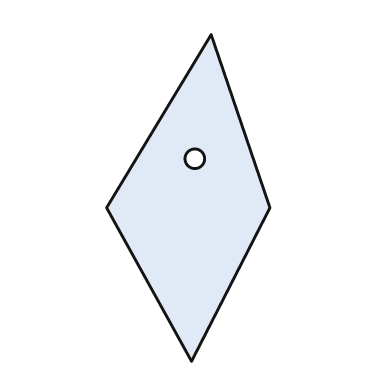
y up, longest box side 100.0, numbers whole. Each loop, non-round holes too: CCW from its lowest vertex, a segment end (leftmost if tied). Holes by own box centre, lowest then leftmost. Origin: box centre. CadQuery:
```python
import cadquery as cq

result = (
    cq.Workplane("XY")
    .moveTo(1.0, -50.0)
    .lineTo(25.0, -3.0)
    .lineTo(7.0, 50.0)
    .lineTo(-25.0, -3.0)
    .close()
    .moveTo(2.0, 12.0)
    .circle(3.0)
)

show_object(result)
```